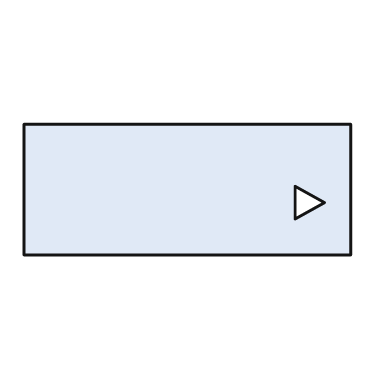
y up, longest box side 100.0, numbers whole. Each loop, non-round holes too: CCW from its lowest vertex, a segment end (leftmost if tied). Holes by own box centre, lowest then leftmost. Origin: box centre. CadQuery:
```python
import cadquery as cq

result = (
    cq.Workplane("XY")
    .moveTo(-50.0, -20.0)
    .lineTo(50.0, -20.0)
    .lineTo(50.0, 20.0)
    .lineTo(-50.0, 20.0)
    .close()
    .moveTo(33.0, -9.0)
    .lineTo(42.0, -4.0)
    .lineTo(33.0, 1.0)
    .close()
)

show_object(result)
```